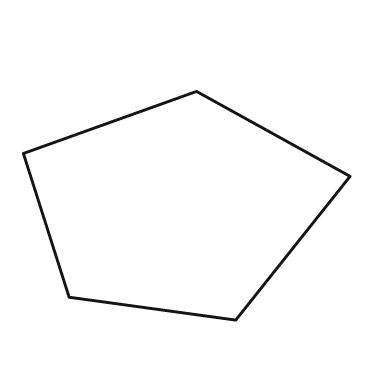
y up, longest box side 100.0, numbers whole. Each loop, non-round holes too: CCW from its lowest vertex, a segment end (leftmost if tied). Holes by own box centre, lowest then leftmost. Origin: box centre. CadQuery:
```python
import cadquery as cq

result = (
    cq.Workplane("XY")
    .moveTo(15.0, -35.0)
    .lineTo(50.0, 9.0)
    .lineTo(3.0, 35.0)
    .lineTo(-50.0, 16.0)
    .lineTo(-36.0, -28.0)
    .close()
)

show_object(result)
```